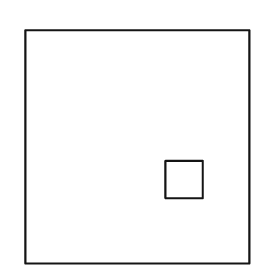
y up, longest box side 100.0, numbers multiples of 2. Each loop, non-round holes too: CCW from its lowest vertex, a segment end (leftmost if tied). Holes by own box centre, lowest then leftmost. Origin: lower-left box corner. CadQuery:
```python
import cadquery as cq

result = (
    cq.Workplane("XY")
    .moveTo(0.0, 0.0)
    .lineTo(96.0, 0.0)
    .lineTo(96.0, 100.0)
    .lineTo(0.0, 100.0)
    .close()
    .moveTo(60.0, 28.0)
    .lineTo(76.0, 28.0)
    .lineTo(76.0, 44.0)
    .lineTo(60.0, 44.0)
    .close()
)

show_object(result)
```